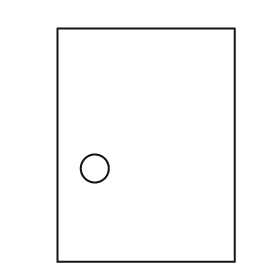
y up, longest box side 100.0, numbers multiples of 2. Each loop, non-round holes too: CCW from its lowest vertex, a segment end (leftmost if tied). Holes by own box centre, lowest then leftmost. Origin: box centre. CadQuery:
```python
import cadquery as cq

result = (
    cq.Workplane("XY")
    .moveTo(-38.0, -50.0)
    .lineTo(38.0, -50.0)
    .lineTo(38.0, 50.0)
    .lineTo(-38.0, 50.0)
    .close()
    .moveTo(-22.0, -10.0)
    .circle(6.0)
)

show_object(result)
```